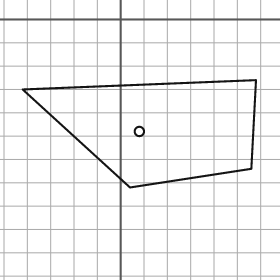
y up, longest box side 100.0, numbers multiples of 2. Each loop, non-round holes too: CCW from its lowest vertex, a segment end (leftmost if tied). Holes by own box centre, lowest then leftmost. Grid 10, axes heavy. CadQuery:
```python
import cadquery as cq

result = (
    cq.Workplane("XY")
    .moveTo(4.0, -72.0)
    .lineTo(56.0, -64.0)
    .lineTo(58.0, -26.0)
    .lineTo(-42.0, -30.0)
    .close()
    .moveTo(8.0, -48.0)
    .circle(2.0)
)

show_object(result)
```